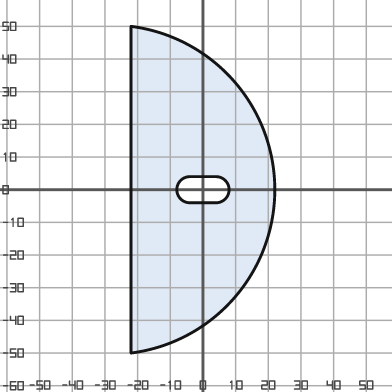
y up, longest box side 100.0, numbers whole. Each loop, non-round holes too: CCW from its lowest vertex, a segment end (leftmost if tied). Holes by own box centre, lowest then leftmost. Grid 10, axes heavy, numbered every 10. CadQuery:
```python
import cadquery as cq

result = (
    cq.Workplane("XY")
    .moveTo(-22.0, -50.0)
    .threePointArc((22.0, 0.0), (-22.0, 50.0))
    .close()
    .moveTo(-4.0, -4.0)
    .lineTo(4.0, -4.0)
    .threePointArc((8.0, 0.0), (4.0, 4.0))
    .lineTo(-4.0, 4.0)
    .threePointArc((-8.0, 0.0), (-4.0, -4.0))
    .close()
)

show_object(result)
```